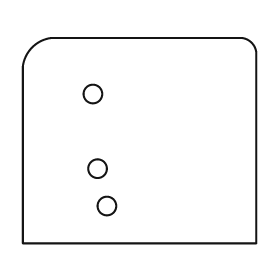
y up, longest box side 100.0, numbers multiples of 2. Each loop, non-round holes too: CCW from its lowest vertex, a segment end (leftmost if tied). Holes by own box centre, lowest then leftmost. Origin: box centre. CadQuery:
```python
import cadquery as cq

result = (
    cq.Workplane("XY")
    .moveTo(-50.0, -44.0)
    .lineTo(50.0, -44.0)
    .lineTo(50.0, 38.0)
    .threePointArc((48.0, 42.0), (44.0, 44.0))
    .lineTo(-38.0, 44.0)
    .threePointArc((-46.0, 40.0), (-50.0, 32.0))
    .close()
    .moveTo(-14.0, -28.0)
    .circle(4.0)
    .moveTo(-18.0, -12.0)
    .circle(4.0)
    .moveTo(-20.0, 20.0)
    .circle(4.0)
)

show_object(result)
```